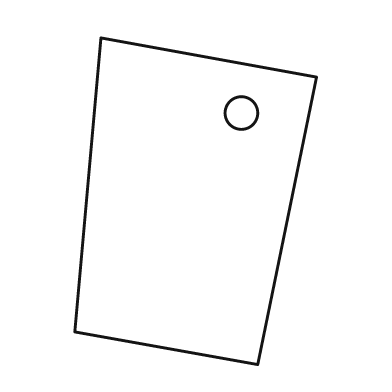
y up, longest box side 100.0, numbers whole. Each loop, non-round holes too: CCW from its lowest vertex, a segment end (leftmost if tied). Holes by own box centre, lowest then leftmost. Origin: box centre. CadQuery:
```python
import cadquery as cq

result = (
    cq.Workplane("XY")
    .moveTo(19.0, -50.0)
    .lineTo(37.0, 38.0)
    .lineTo(-29.0, 50.0)
    .lineTo(-37.0, -40.0)
    .close()
    .moveTo(14.0, 27.0)
    .circle(5.0)
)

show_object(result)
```